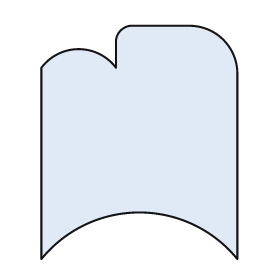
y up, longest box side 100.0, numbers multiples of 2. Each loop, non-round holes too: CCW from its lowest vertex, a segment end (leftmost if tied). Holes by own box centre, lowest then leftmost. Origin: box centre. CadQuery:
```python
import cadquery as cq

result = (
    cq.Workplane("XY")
    .moveTo(-42.0, -50.0)
    .threePointArc((0.0, -30.0), (42.0, -50.0))
    .lineTo(42.0, 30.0)
    .threePointArc((36.0, 44.0), (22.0, 50.0))
    .lineTo(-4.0, 50.0)
    .threePointArc((-8.0, 48.0), (-10.0, 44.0))
    .lineTo(-10.0, 32.0)
    .threePointArc((-26.0, 40.0), (-42.0, 32.0))
    .close()
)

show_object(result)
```